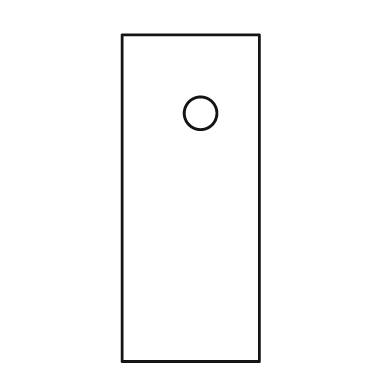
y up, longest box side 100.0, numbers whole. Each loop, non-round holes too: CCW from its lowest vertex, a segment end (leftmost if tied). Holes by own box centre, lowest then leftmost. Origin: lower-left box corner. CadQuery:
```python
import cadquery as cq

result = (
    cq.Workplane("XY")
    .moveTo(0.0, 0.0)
    .lineTo(42.0, 0.0)
    .lineTo(42.0, 100.0)
    .lineTo(0.0, 100.0)
    .close()
    .moveTo(24.0, 76.0)
    .circle(5.0)
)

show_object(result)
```